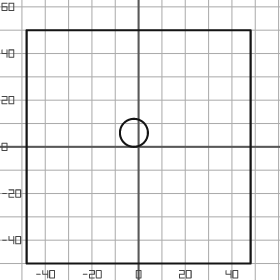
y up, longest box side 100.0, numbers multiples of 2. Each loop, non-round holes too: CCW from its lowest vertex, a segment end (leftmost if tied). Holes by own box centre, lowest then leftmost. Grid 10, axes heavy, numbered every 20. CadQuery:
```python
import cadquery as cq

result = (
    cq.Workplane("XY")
    .moveTo(-48.0, -50.0)
    .lineTo(48.0, -50.0)
    .lineTo(48.0, 50.0)
    .lineTo(-48.0, 50.0)
    .close()
    .moveTo(-2.0, 6.0)
    .circle(6.0)
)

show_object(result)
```